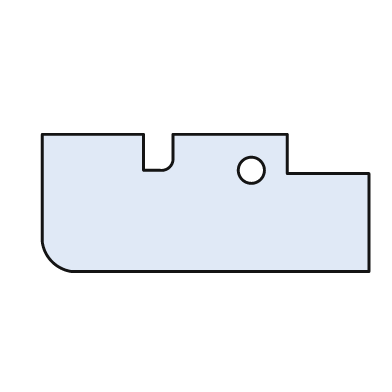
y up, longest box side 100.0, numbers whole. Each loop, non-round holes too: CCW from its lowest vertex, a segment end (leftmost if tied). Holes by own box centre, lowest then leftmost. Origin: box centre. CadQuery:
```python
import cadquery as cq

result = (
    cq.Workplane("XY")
    .moveTo(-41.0, -21.0)
    .lineTo(50.0, -21.0)
    .lineTo(50.0, 9.0)
    .lineTo(25.0, 9.0)
    .lineTo(25.0, 21.0)
    .lineTo(-10.0, 21.0)
    .lineTo(-10.0, 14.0)
    .threePointArc((-11.0, 11.0), (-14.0, 10.0))
    .lineTo(-19.0, 10.0)
    .lineTo(-19.0, 21.0)
    .lineTo(-50.0, 21.0)
    .lineTo(-50.0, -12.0)
    .threePointArc((-47.0, -18.0), (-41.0, -21.0))
    .close()
    .moveTo(14.0, 10.0)
    .circle(4.0)
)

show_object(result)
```